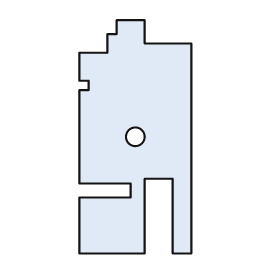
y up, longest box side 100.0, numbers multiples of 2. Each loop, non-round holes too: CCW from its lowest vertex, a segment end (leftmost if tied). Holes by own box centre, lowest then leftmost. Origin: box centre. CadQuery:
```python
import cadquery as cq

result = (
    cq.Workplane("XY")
    .moveTo(-24.0, -50.0)
    .lineTo(4.0, -50.0)
    .lineTo(4.0, -18.0)
    .lineTo(16.0, -18.0)
    .lineTo(16.0, -50.0)
    .lineTo(24.0, -50.0)
    .lineTo(24.0, 40.0)
    .lineTo(4.0, 40.0)
    .lineTo(4.0, 50.0)
    .lineTo(-8.0, 50.0)
    .lineTo(-8.0, 44.0)
    .lineTo(-12.0, 44.0)
    .lineTo(-12.0, 36.0)
    .lineTo(-24.0, 36.0)
    .lineTo(-24.0, 24.0)
    .lineTo(-20.0, 24.0)
    .lineTo(-20.0, 20.0)
    .lineTo(-24.0, 20.0)
    .lineTo(-24.0, -20.0)
    .lineTo(-2.0, -20.0)
    .lineTo(-2.0, -26.0)
    .lineTo(-24.0, -26.0)
    .close()
    .moveTo(0.0, 0.0)
    .circle(4.0)
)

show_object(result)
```